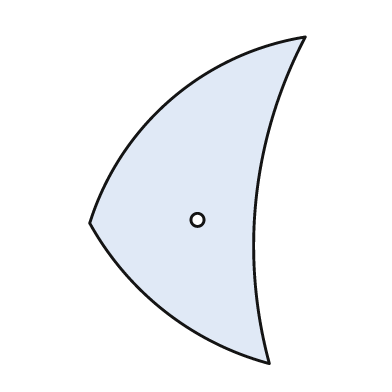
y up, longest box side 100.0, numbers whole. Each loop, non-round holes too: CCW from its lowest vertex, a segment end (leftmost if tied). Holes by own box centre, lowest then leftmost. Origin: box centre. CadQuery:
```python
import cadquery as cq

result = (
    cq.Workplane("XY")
    .moveTo(22.0, -50.0)
    .threePointArc((18.0, 1.0), (33.0, 50.0))
    .threePointArc((-8.0, 31.0), (-33.0, -7.0))
    .threePointArc((-10.0, -34.0), (22.0, -50.0))
    .close()
    .moveTo(0.0, -6.0)
    .circle(2.0)
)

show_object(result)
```